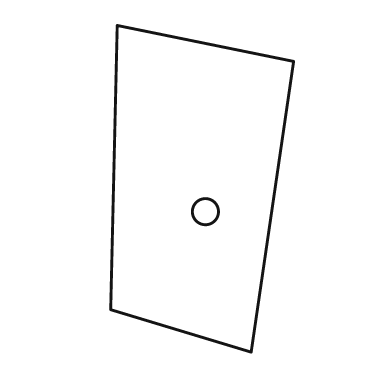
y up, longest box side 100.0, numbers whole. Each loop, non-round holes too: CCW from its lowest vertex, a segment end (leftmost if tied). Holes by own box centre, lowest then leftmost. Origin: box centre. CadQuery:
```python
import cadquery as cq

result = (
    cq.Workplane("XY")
    .moveTo(15.0, -50.0)
    .lineTo(28.0, 39.0)
    .lineTo(-26.0, 50.0)
    .lineTo(-28.0, -37.0)
    .close()
    .moveTo(1.0, -7.0)
    .circle(4.0)
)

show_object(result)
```